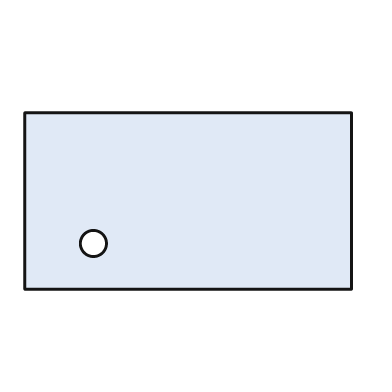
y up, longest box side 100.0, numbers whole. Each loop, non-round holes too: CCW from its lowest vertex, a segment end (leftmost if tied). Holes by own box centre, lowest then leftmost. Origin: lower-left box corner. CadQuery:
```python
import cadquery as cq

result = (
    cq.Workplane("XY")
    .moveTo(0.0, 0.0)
    .lineTo(100.0, 0.0)
    .lineTo(100.0, 54.0)
    .lineTo(0.0, 54.0)
    .close()
    .moveTo(21.0, 14.0)
    .circle(4.0)
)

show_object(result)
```